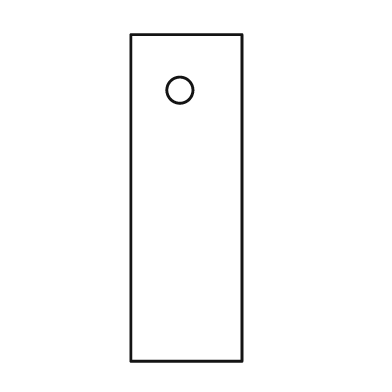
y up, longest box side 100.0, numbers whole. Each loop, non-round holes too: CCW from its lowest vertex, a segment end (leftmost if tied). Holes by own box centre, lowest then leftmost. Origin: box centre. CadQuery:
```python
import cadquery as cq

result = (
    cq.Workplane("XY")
    .moveTo(-17.0, -50.0)
    .lineTo(17.0, -50.0)
    .lineTo(17.0, 50.0)
    .lineTo(-17.0, 50.0)
    .close()
    .moveTo(-2.0, 33.0)
    .circle(4.0)
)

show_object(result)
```